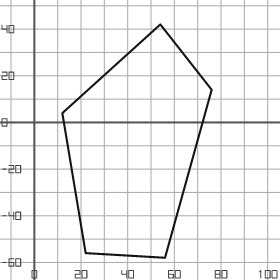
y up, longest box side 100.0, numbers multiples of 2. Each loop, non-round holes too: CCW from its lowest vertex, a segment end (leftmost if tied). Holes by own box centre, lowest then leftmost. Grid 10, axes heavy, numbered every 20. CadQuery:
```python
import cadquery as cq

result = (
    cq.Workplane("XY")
    .moveTo(56.0, -58.0)
    .lineTo(76.0, 14.0)
    .lineTo(54.0, 42.0)
    .lineTo(12.0, 4.0)
    .lineTo(22.0, -56.0)
    .close()
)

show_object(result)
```